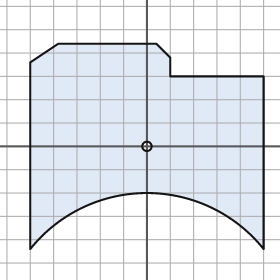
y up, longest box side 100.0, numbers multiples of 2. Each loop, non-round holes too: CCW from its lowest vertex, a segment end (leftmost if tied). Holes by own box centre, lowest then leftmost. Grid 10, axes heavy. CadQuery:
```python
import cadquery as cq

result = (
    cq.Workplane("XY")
    .moveTo(-50.0, -44.0)
    .threePointArc((0.0, -20.0), (50.0, -44.0))
    .lineTo(50.0, 30.0)
    .lineTo(10.0, 30.0)
    .lineTo(10.0, 38.0)
    .lineTo(4.0, 44.0)
    .lineTo(-38.0, 44.0)
    .lineTo(-50.0, 36.0)
    .close()
    .moveTo(0.0, 0.0)
    .circle(2.0)
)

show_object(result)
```